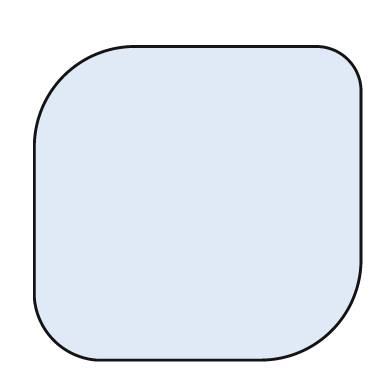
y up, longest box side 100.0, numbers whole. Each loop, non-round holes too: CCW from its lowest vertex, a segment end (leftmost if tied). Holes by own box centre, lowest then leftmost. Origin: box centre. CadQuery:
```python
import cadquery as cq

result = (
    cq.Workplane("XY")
    .moveTo(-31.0, -48.0)
    .lineTo(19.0, -48.0)
    .threePointArc((41.0, -39.0), (50.0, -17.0))
    .lineTo(50.0, 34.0)
    .threePointArc((46.0, 44.0), (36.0, 48.0))
    .lineTo(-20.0, 48.0)
    .threePointArc((-41.0, 39.0), (-50.0, 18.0))
    .lineTo(-50.0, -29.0)
    .threePointArc((-44.0, -42.0), (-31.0, -48.0))
    .close()
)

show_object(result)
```